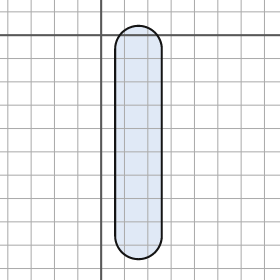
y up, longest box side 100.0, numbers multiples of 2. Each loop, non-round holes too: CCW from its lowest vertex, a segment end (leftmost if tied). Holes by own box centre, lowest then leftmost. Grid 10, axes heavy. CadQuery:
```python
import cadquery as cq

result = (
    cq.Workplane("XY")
    .moveTo(6.0, -86.0)
    .threePointArc((16.0, -96.0), (26.0, -86.0))
    .lineTo(26.0, -6.0)
    .threePointArc((16.0, 4.0), (6.0, -6.0))
    .close()
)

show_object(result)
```